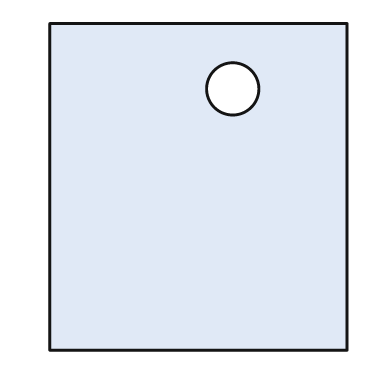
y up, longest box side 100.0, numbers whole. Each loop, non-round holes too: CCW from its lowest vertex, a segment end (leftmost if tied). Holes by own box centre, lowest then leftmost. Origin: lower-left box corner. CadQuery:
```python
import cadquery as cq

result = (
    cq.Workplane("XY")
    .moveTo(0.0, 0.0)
    .lineTo(91.0, 0.0)
    .lineTo(91.0, 100.0)
    .lineTo(0.0, 100.0)
    .close()
    .moveTo(56.0, 80.0)
    .circle(8.0)
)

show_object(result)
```